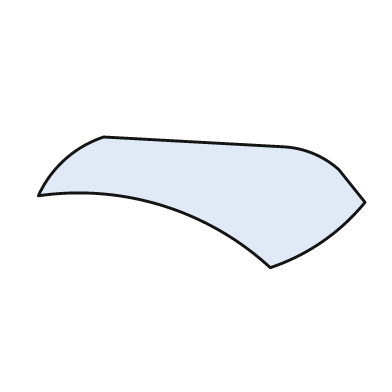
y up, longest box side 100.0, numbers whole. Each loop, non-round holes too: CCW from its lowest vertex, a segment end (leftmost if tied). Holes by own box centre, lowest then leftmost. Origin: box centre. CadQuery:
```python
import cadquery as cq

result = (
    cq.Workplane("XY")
    .moveTo(21.0, -20.0)
    .threePointArc((37.0, -12.0), (50.0, 0.0))
    .lineTo(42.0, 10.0)
    .threePointArc((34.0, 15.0), (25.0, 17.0))
    .lineTo(-30.0, 20.0)
    .threePointArc((-42.0, 13.0), (-50.0, 2.0))
    .threePointArc((-12.0, -1.0), (21.0, -20.0))
    .close()
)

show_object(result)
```